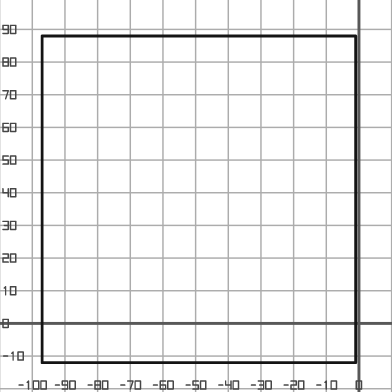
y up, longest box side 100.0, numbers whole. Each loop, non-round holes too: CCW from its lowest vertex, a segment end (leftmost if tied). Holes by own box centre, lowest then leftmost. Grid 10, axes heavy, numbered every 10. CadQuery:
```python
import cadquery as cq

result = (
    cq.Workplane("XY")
    .moveTo(-97.0, -12.0)
    .lineTo(-1.0, -12.0)
    .lineTo(-1.0, 88.0)
    .lineTo(-97.0, 88.0)
    .close()
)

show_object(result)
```